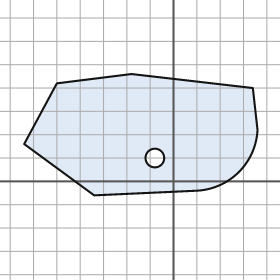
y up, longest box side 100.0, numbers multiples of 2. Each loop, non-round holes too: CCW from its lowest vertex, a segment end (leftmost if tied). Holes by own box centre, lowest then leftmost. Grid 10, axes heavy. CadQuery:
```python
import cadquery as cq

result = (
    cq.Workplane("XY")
    .moveTo(-34.0, -6.0)
    .lineTo(10.0, -4.0)
    .threePointArc((28.0, 4.0), (36.0, 22.0))
    .lineTo(34.0, 40.0)
    .lineTo(-18.0, 46.0)
    .lineTo(-50.0, 42.0)
    .lineTo(-64.0, 16.0)
    .close()
    .moveTo(-8.0, 10.0)
    .circle(4.0)
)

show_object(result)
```